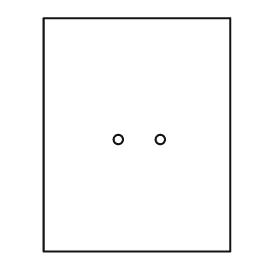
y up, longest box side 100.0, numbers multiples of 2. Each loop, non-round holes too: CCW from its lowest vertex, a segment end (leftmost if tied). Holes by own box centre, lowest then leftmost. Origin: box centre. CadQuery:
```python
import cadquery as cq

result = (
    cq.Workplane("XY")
    .moveTo(-40.0, -50.0)
    .lineTo(40.0, -50.0)
    .lineTo(40.0, 50.0)
    .lineTo(-40.0, 50.0)
    .close()
    .moveTo(-8.0, -2.0)
    .circle(2.0)
    .moveTo(10.0, -2.0)
    .circle(2.0)
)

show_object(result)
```